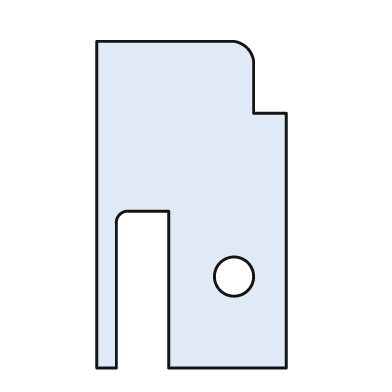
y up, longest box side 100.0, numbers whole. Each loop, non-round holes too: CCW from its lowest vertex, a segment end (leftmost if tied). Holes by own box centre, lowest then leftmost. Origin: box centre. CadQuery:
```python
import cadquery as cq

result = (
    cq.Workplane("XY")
    .moveTo(-29.0, -50.0)
    .lineTo(-23.0, -50.0)
    .lineTo(-23.0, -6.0)
    .threePointArc((-22.0, -3.0), (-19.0, -2.0))
    .lineTo(-7.0, -2.0)
    .lineTo(-7.0, -50.0)
    .lineTo(29.0, -50.0)
    .lineTo(29.0, 28.0)
    .lineTo(19.0, 28.0)
    .lineTo(19.0, 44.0)
    .threePointArc((17.0, 48.0), (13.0, 50.0))
    .lineTo(-29.0, 50.0)
    .close()
    .moveTo(13.0, -22.0)
    .circle(6.0)
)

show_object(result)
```